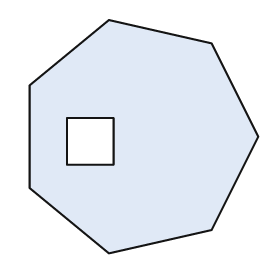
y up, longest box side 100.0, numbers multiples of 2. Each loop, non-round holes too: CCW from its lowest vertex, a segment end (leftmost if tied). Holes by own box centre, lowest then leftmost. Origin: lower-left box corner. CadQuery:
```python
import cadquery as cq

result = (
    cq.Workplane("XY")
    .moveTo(34.0, 0.0)
    .lineTo(78.0, 10.0)
    .lineTo(98.0, 50.0)
    .lineTo(78.0, 90.0)
    .lineTo(34.0, 100.0)
    .lineTo(0.0, 72.0)
    .lineTo(0.0, 28.0)
    .close()
    .moveTo(16.0, 38.0)
    .lineTo(36.0, 38.0)
    .lineTo(36.0, 58.0)
    .lineTo(16.0, 58.0)
    .close()
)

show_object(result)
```